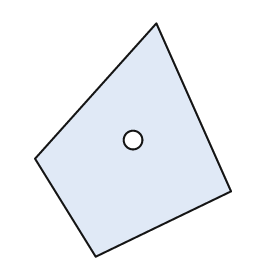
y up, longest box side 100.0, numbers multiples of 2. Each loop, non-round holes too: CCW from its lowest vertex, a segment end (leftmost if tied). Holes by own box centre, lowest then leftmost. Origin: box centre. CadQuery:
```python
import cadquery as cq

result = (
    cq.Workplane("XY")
    .moveTo(-16.0, -50.0)
    .lineTo(42.0, -22.0)
    .lineTo(10.0, 50.0)
    .lineTo(-42.0, -8.0)
    .close()
    .moveTo(0.0, 0.0)
    .circle(4.0)
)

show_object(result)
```